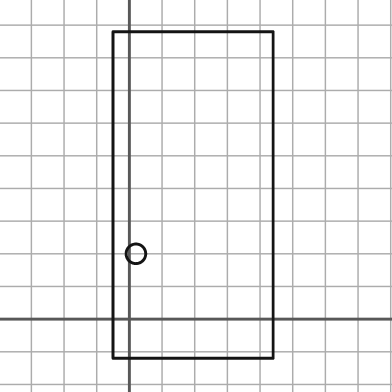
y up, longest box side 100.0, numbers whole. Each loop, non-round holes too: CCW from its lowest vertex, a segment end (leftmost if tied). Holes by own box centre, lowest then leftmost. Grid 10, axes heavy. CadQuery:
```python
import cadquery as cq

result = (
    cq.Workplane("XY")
    .moveTo(-5.0, -12.0)
    .lineTo(44.0, -12.0)
    .lineTo(44.0, 88.0)
    .lineTo(-5.0, 88.0)
    .close()
    .moveTo(2.0, 20.0)
    .circle(3.0)
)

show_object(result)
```